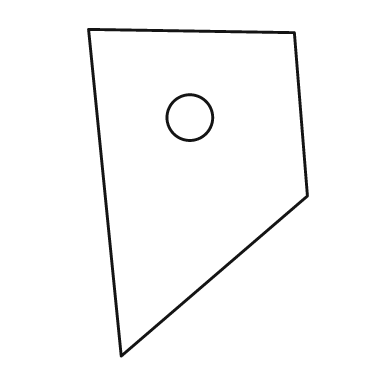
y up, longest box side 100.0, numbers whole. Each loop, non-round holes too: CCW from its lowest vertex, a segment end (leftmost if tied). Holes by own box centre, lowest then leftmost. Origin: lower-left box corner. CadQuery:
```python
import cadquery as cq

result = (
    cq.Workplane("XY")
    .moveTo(10.0, 0.0)
    .lineTo(67.0, 49.0)
    .lineTo(63.0, 99.0)
    .lineTo(0.0, 100.0)
    .close()
    .moveTo(31.0, 73.0)
    .circle(7.0)
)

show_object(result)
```